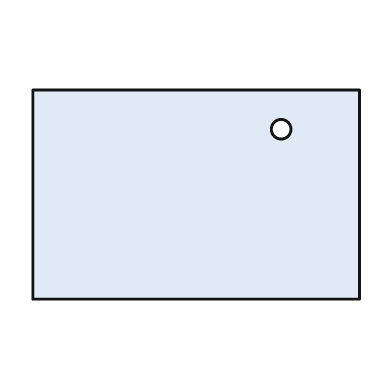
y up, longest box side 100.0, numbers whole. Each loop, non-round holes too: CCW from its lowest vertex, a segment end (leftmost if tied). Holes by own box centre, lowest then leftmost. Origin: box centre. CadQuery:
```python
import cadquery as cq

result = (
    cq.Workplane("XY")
    .moveTo(-50.0, -32.0)
    .lineTo(50.0, -32.0)
    .lineTo(50.0, 32.0)
    .lineTo(-50.0, 32.0)
    .close()
    .moveTo(26.0, 20.0)
    .circle(3.0)
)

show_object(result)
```